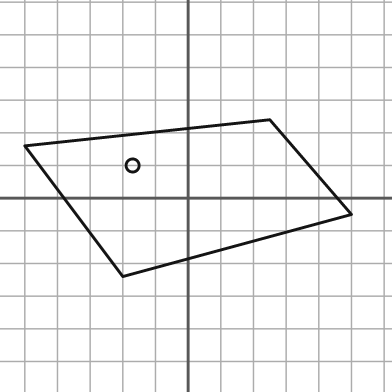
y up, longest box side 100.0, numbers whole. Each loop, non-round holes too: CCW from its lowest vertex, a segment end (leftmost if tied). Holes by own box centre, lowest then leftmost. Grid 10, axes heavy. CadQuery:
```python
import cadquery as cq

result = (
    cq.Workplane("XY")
    .moveTo(-20.0, -24.0)
    .lineTo(50.0, -5.0)
    .lineTo(25.0, 24.0)
    .lineTo(-50.0, 16.0)
    .close()
    .moveTo(-17.0, 10.0)
    .circle(2.0)
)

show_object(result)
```